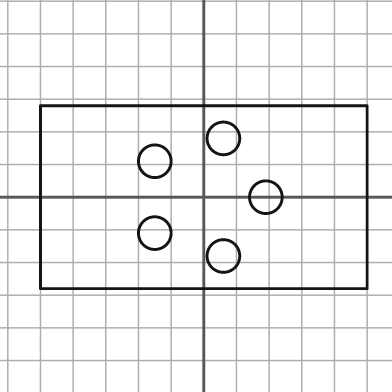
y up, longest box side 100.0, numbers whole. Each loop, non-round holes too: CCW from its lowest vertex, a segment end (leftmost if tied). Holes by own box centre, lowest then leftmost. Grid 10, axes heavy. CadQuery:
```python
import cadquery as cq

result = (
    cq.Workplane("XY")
    .moveTo(-50.0, -28.0)
    .lineTo(50.0, -28.0)
    .lineTo(50.0, 28.0)
    .lineTo(-50.0, 28.0)
    .close()
    .moveTo(6.0, -18.0)
    .circle(5.0)
    .moveTo(-15.0, -11.0)
    .circle(5.0)
    .moveTo(19.0, 0.0)
    .circle(5.0)
    .moveTo(-15.0, 11.0)
    .circle(5.0)
    .moveTo(6.0, 18.0)
    .circle(5.0)
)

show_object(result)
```